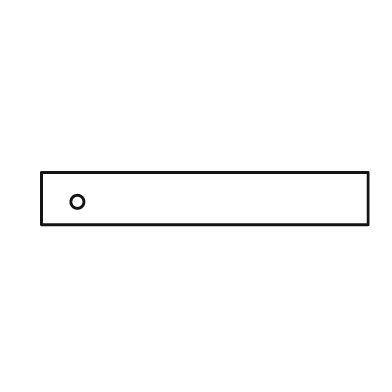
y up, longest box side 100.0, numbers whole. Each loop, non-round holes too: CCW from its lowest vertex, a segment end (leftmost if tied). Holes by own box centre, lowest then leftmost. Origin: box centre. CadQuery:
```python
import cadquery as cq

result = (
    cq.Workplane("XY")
    .moveTo(-50.0, -8.0)
    .lineTo(50.0, -8.0)
    .lineTo(50.0, 8.0)
    .lineTo(-50.0, 8.0)
    .close()
    .moveTo(-39.0, -1.0)
    .circle(2.0)
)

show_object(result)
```